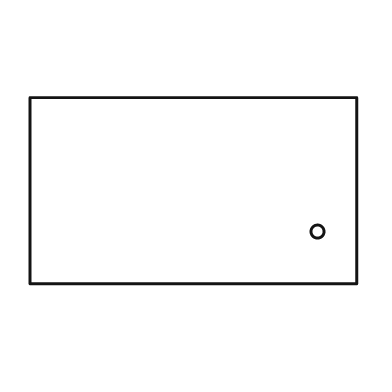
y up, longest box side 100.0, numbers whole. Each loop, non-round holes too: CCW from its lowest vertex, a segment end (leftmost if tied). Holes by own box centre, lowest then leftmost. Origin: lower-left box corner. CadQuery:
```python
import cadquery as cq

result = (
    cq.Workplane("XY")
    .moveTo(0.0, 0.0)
    .lineTo(100.0, 0.0)
    .lineTo(100.0, 57.0)
    .lineTo(0.0, 57.0)
    .close()
    .moveTo(88.0, 16.0)
    .circle(2.0)
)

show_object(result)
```